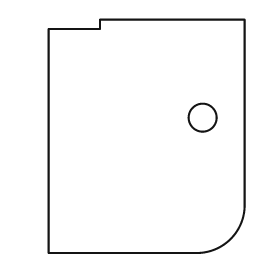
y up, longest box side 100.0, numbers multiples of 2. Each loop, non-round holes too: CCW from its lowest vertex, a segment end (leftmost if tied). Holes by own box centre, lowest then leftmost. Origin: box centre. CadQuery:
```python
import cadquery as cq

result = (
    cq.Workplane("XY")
    .moveTo(-42.0, -50.0)
    .lineTo(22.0, -50.0)
    .threePointArc((36.0, -44.0), (42.0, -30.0))
    .lineTo(42.0, 50.0)
    .lineTo(-20.0, 50.0)
    .lineTo(-20.0, 46.0)
    .lineTo(-42.0, 46.0)
    .close()
    .moveTo(24.0, 8.0)
    .circle(6.0)
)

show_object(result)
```